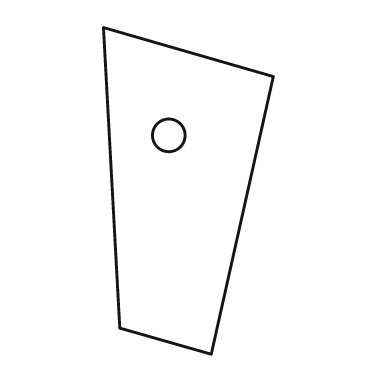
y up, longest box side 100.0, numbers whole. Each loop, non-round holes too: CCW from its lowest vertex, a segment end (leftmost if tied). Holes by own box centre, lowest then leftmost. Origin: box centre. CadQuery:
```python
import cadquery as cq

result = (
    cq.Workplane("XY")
    .moveTo(7.0, -50.0)
    .lineTo(26.0, 35.0)
    .lineTo(-26.0, 50.0)
    .lineTo(-21.0, -42.0)
    .close()
    .moveTo(-6.0, 17.0)
    .circle(5.0)
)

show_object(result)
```